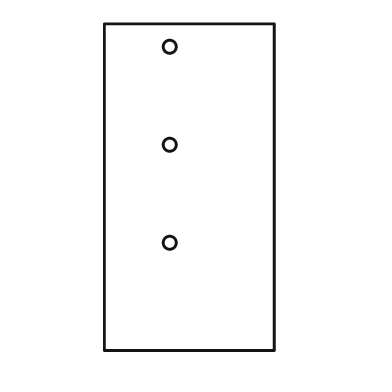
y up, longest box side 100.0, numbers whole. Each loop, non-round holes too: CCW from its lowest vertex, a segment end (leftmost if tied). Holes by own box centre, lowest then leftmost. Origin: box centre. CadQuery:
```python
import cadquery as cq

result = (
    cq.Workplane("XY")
    .moveTo(-26.0, -50.0)
    .lineTo(26.0, -50.0)
    .lineTo(26.0, 50.0)
    .lineTo(-26.0, 50.0)
    .close()
    .moveTo(-6.0, -17.0)
    .circle(2.0)
    .moveTo(-6.0, 13.0)
    .circle(2.0)
    .moveTo(-6.0, 43.0)
    .circle(2.0)
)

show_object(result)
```